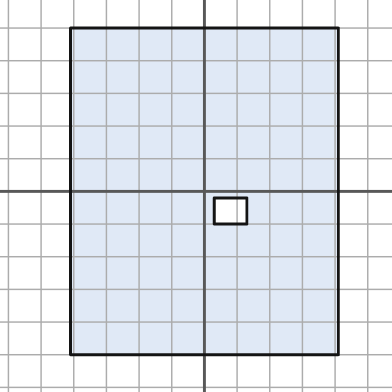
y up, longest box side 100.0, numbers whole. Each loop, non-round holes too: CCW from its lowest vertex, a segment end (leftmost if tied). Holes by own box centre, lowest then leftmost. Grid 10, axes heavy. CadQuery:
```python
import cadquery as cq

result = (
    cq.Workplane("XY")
    .moveTo(-41.0, -50.0)
    .lineTo(41.0, -50.0)
    .lineTo(41.0, 50.0)
    .lineTo(-41.0, 50.0)
    .close()
    .moveTo(3.0, -10.0)
    .lineTo(13.0, -10.0)
    .lineTo(13.0, -2.0)
    .lineTo(3.0, -2.0)
    .close()
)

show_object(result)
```